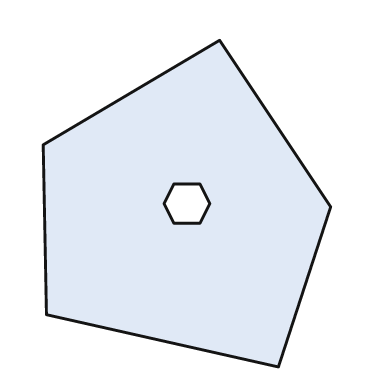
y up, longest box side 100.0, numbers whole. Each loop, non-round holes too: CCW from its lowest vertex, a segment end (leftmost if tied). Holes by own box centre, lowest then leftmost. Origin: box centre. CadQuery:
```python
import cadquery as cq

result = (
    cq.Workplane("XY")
    .moveTo(28.0, -50.0)
    .lineTo(44.0, -1.0)
    .lineTo(10.0, 50.0)
    .lineTo(-44.0, 18.0)
    .lineTo(-43.0, -34.0)
    .close()
    .moveTo(-4.0, -6.0)
    .lineTo(4.0, -6.0)
    .lineTo(7.0, 0.0)
    .lineTo(4.0, 6.0)
    .lineTo(-4.0, 6.0)
    .lineTo(-7.0, 0.0)
    .close()
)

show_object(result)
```